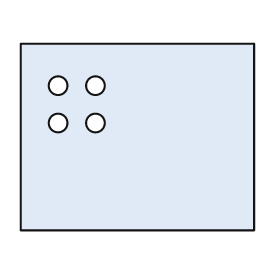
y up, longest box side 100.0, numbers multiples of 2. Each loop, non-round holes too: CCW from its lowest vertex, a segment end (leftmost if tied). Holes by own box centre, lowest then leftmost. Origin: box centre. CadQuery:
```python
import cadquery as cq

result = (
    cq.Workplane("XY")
    .moveTo(-50.0, -40.0)
    .lineTo(50.0, -40.0)
    .lineTo(50.0, 40.0)
    .lineTo(-50.0, 40.0)
    .close()
    .moveTo(-34.0, 6.0)
    .circle(4.0)
    .moveTo(-18.0, 6.0)
    .circle(4.0)
    .moveTo(-34.0, 22.0)
    .circle(4.0)
    .moveTo(-18.0, 22.0)
    .circle(4.0)
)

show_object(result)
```